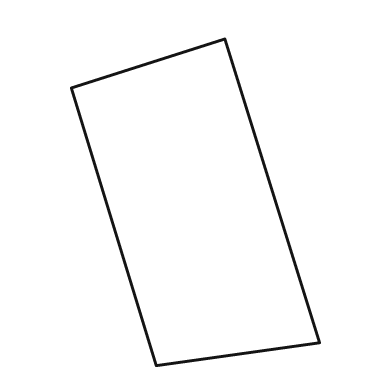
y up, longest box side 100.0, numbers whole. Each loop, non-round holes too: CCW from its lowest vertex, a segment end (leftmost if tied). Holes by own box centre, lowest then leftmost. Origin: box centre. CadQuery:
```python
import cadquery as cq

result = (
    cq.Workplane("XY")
    .moveTo(-12.0, -50.0)
    .lineTo(38.0, -43.0)
    .lineTo(9.0, 50.0)
    .lineTo(-38.0, 35.0)
    .close()
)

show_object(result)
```